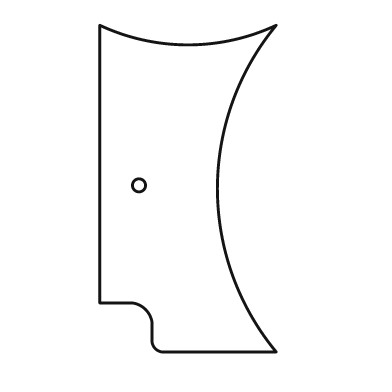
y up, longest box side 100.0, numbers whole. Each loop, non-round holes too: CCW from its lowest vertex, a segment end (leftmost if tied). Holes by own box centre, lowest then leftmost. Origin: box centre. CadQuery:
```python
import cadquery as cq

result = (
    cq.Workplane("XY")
    .moveTo(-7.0, -50.0)
    .lineTo(27.0, -50.0)
    .threePointArc((9.0, 0.0), (27.0, 50.0))
    .threePointArc((0.0, 44.0), (-27.0, 50.0))
    .lineTo(-27.0, -35.0)
    .lineTo(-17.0, -35.0)
    .threePointArc((-13.0, -37.0), (-11.0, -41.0))
    .lineTo(-11.0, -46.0)
    .threePointArc((-10.0, -49.0), (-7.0, -50.0))
    .close()
    .moveTo(-15.0, 1.0)
    .circle(2.0)
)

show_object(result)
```